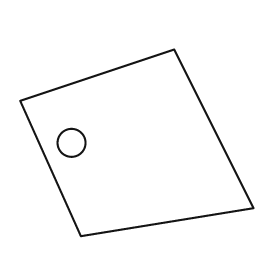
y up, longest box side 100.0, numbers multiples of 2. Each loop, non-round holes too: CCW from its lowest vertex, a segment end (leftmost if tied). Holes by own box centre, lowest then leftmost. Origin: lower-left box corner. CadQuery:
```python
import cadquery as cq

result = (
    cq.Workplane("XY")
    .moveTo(26.0, 0.0)
    .lineTo(100.0, 12.0)
    .lineTo(66.0, 80.0)
    .lineTo(0.0, 58.0)
    .close()
    .moveTo(22.0, 40.0)
    .circle(6.0)
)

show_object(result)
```